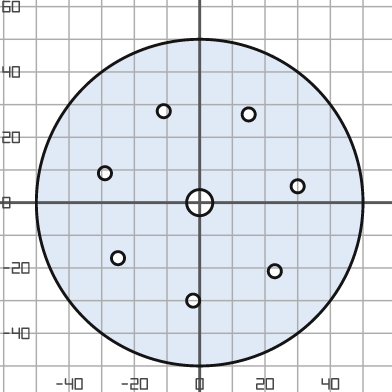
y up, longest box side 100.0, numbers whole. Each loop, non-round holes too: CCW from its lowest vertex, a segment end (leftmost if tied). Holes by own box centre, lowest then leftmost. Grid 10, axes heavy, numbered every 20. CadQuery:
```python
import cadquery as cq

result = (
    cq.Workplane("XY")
    .moveTo(0.0, 0.0)
    .circle(50.0)
    .moveTo(-2.0, -30.0)
    .circle(2.0)
    .moveTo(23.0, -21.0)
    .circle(2.0)
    .moveTo(-25.0, -17.0)
    .circle(2.0)
    .moveTo(0.0, 0.0)
    .circle(4.0)
    .moveTo(30.0, 5.0)
    .circle(2.0)
    .moveTo(-29.0, 9.0)
    .circle(2.0)
    .moveTo(15.0, 27.0)
    .circle(2.0)
    .moveTo(-11.0, 28.0)
    .circle(2.0)
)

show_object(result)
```